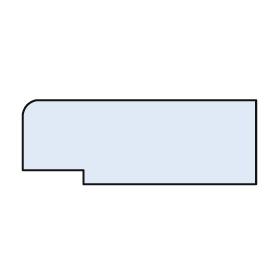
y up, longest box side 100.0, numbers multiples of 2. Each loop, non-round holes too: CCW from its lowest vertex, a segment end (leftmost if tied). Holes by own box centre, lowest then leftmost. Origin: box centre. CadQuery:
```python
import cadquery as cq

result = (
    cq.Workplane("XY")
    .moveTo(-24.0, -18.0)
    .lineTo(50.0, -18.0)
    .lineTo(50.0, 18.0)
    .lineTo(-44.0, 18.0)
    .threePointArc((-48.0, 16.0), (-50.0, 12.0))
    .lineTo(-50.0, -12.0)
    .lineTo(-24.0, -12.0)
    .close()
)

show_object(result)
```